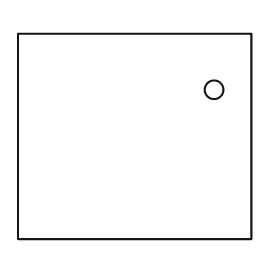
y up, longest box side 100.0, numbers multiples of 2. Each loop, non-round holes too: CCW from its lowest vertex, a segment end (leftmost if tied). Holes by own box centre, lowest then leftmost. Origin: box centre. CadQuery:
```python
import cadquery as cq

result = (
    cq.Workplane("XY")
    .moveTo(-50.0, -44.0)
    .lineTo(50.0, -44.0)
    .lineTo(50.0, 44.0)
    .lineTo(-50.0, 44.0)
    .close()
    .moveTo(34.0, 20.0)
    .circle(4.0)
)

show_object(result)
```